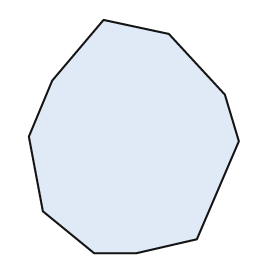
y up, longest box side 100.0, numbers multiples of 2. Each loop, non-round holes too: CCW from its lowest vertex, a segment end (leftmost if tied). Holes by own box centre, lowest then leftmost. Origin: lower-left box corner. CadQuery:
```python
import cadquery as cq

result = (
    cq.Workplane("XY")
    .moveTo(28.0, 0.0)
    .lineTo(46.0, 0.0)
    .lineTo(72.0, 6.0)
    .lineTo(90.0, 48.0)
    .lineTo(84.0, 68.0)
    .lineTo(60.0, 94.0)
    .lineTo(32.0, 100.0)
    .lineTo(10.0, 74.0)
    .lineTo(0.0, 50.0)
    .lineTo(6.0, 18.0)
    .close()
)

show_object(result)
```